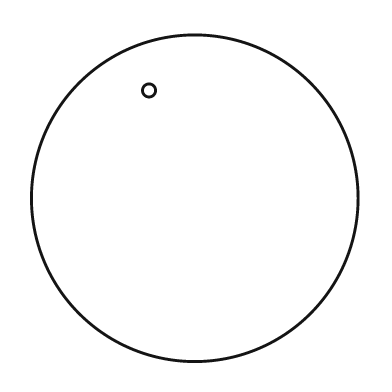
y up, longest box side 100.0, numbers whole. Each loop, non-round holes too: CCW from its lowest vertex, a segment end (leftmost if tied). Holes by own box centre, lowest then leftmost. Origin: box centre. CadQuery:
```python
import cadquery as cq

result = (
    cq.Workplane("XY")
    .moveTo(0.0, 0.0)
    .circle(50.0)
    .moveTo(-14.0, 33.0)
    .circle(2.0)
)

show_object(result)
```